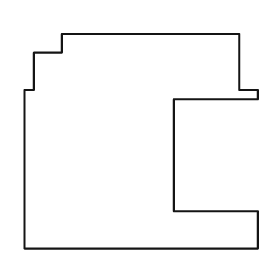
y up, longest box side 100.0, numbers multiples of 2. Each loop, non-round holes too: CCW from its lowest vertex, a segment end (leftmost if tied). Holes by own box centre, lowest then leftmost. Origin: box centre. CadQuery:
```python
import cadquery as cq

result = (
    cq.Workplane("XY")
    .moveTo(-50.0, -46.0)
    .lineTo(50.0, -46.0)
    .lineTo(50.0, -30.0)
    .lineTo(14.0, -30.0)
    .lineTo(14.0, 18.0)
    .lineTo(50.0, 18.0)
    .lineTo(50.0, 22.0)
    .lineTo(42.0, 22.0)
    .lineTo(42.0, 46.0)
    .lineTo(-34.0, 46.0)
    .lineTo(-34.0, 38.0)
    .lineTo(-46.0, 38.0)
    .lineTo(-46.0, 22.0)
    .lineTo(-50.0, 22.0)
    .close()
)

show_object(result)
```